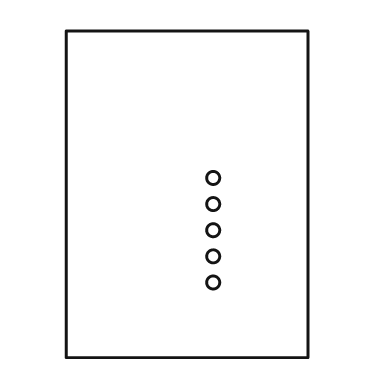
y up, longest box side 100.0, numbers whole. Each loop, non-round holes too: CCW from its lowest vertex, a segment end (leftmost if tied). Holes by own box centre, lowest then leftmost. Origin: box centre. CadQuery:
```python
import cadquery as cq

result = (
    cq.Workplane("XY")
    .moveTo(-37.0, -50.0)
    .lineTo(37.0, -50.0)
    .lineTo(37.0, 50.0)
    .lineTo(-37.0, 50.0)
    .close()
    .moveTo(8.0, -27.0)
    .circle(2.0)
    .moveTo(8.0, -19.0)
    .circle(2.0)
    .moveTo(8.0, -11.0)
    .circle(2.0)
    .moveTo(8.0, -3.0)
    .circle(2.0)
    .moveTo(8.0, 5.0)
    .circle(2.0)
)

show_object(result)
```